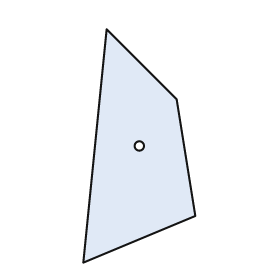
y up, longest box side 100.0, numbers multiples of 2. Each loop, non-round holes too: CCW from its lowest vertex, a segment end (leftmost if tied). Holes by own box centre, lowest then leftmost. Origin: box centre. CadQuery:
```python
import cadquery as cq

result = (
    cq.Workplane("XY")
    .moveTo(-24.0, -50.0)
    .lineTo(24.0, -30.0)
    .lineTo(16.0, 20.0)
    .lineTo(-14.0, 50.0)
    .close()
    .moveTo(0.0, 0.0)
    .circle(2.0)
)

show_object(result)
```